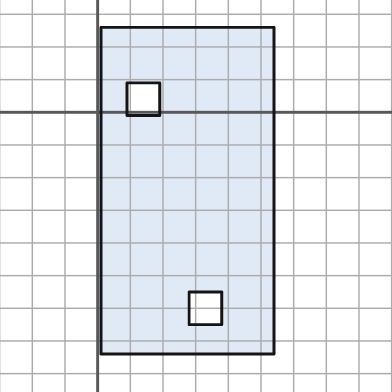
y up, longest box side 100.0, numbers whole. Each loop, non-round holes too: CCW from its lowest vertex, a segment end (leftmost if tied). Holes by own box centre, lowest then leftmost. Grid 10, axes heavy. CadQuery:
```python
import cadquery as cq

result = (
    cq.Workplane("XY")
    .moveTo(1.0, -74.0)
    .lineTo(54.0, -74.0)
    .lineTo(54.0, 26.0)
    .lineTo(1.0, 26.0)
    .close()
    .moveTo(28.0, -65.0)
    .lineTo(38.0, -65.0)
    .lineTo(38.0, -55.0)
    .lineTo(28.0, -55.0)
    .close()
    .moveTo(9.0, -1.0)
    .lineTo(19.0, -1.0)
    .lineTo(19.0, 9.0)
    .lineTo(9.0, 9.0)
    .close()
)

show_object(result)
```